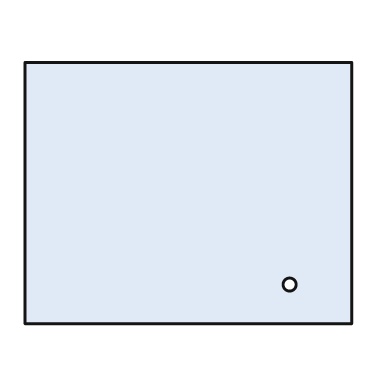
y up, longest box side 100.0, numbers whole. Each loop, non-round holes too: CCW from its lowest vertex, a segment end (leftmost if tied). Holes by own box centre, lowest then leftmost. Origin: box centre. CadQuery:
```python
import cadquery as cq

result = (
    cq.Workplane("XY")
    .moveTo(-50.0, -40.0)
    .lineTo(50.0, -40.0)
    .lineTo(50.0, 40.0)
    .lineTo(-50.0, 40.0)
    .close()
    .moveTo(31.0, -28.0)
    .circle(2.0)
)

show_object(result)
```